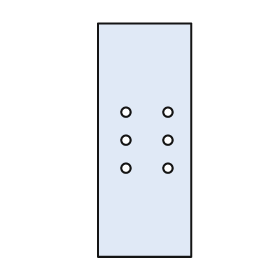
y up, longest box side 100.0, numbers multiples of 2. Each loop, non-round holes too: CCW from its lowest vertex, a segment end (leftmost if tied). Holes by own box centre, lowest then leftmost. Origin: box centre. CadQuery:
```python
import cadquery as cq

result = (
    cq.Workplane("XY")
    .moveTo(-20.0, -50.0)
    .lineTo(20.0, -50.0)
    .lineTo(20.0, 50.0)
    .lineTo(-20.0, 50.0)
    .close()
    .moveTo(-8.0, -12.0)
    .circle(2.0)
    .moveTo(10.0, -12.0)
    .circle(2.0)
    .moveTo(-8.0, 0.0)
    .circle(2.0)
    .moveTo(10.0, 0.0)
    .circle(2.0)
    .moveTo(-8.0, 12.0)
    .circle(2.0)
    .moveTo(10.0, 12.0)
    .circle(2.0)
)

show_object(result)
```